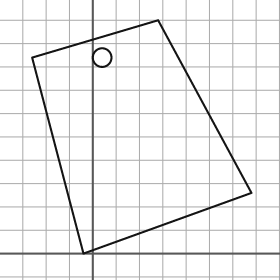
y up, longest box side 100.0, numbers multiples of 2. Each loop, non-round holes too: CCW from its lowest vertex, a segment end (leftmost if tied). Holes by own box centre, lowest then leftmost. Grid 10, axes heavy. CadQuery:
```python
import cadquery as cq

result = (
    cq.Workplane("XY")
    .moveTo(-4.0, 0.0)
    .lineTo(68.0, 26.0)
    .lineTo(28.0, 100.0)
    .lineTo(-26.0, 84.0)
    .close()
    .moveTo(4.0, 84.0)
    .circle(4.0)
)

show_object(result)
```